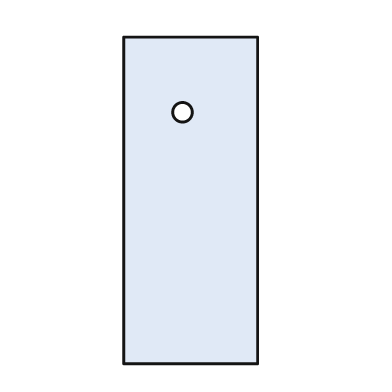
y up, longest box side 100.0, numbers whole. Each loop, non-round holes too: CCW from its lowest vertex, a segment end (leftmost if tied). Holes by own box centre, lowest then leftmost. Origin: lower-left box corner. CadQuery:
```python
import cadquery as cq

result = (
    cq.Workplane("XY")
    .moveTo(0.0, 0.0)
    .lineTo(41.0, 0.0)
    .lineTo(41.0, 100.0)
    .lineTo(0.0, 100.0)
    .close()
    .moveTo(18.0, 77.0)
    .circle(3.0)
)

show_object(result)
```